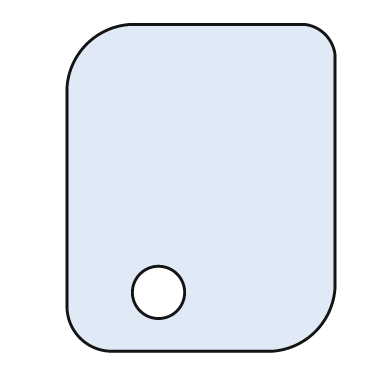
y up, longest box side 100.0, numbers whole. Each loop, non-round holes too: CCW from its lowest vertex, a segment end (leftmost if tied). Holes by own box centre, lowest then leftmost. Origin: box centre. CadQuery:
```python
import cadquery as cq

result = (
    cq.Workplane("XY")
    .moveTo(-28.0, -50.0)
    .lineTo(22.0, -50.0)
    .threePointArc((35.0, -44.0), (41.0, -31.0))
    .lineTo(41.0, 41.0)
    .threePointArc((38.0, 47.0), (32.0, 50.0))
    .lineTo(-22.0, 50.0)
    .threePointArc((-35.0, 44.0), (-41.0, 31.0))
    .lineTo(-41.0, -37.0)
    .threePointArc((-37.0, -46.0), (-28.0, -50.0))
    .close()
    .moveTo(-13.0, -32.0)
    .circle(8.0)
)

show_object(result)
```